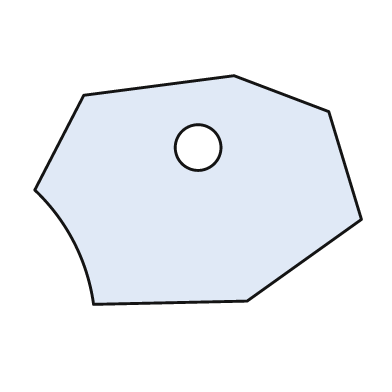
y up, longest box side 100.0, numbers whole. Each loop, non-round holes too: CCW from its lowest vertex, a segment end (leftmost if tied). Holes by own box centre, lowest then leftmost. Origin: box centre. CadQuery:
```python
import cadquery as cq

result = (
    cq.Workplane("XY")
    .moveTo(-32.0, -35.0)
    .lineTo(15.0, -34.0)
    .lineTo(50.0, -9.0)
    .lineTo(40.0, 24.0)
    .lineTo(11.0, 35.0)
    .lineTo(-35.0, 29.0)
    .lineTo(-50.0, 0.0)
    .threePointArc((-38.0, -16.0), (-32.0, -35.0))
    .close()
    .moveTo(0.0, 13.0)
    .circle(7.0)
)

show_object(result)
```